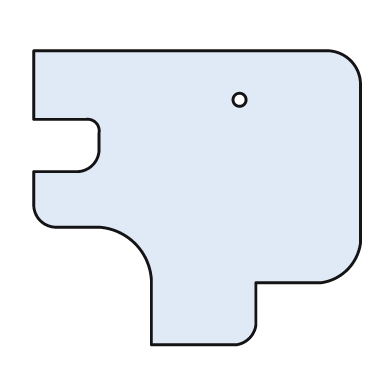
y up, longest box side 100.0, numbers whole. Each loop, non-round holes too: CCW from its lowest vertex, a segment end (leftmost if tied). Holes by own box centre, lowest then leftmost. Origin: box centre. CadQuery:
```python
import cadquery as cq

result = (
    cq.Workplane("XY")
    .moveTo(-14.0, -45.0)
    .lineTo(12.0, -45.0)
    .threePointArc((16.0, -43.0), (18.0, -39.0))
    .lineTo(18.0, -26.0)
    .lineTo(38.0, -26.0)
    .threePointArc((46.0, -22.0), (50.0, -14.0))
    .lineTo(50.0, 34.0)
    .threePointArc((47.0, 42.0), (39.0, 45.0))
    .lineTo(-50.0, 45.0)
    .lineTo(-50.0, 24.0)
    .lineTo(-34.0, 24.0)
    .threePointArc((-31.0, 23.0), (-30.0, 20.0))
    .lineTo(-30.0, 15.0)
    .threePointArc((-32.0, 10.0), (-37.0, 8.0))
    .lineTo(-50.0, 8.0)
    .lineTo(-50.0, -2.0)
    .threePointArc((-48.0, -7.0), (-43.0, -9.0))
    .lineTo(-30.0, -9.0)
    .threePointArc((-19.0, -14.0), (-14.0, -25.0))
    .close()
    .moveTo(13.0, 30.0)
    .circle(2.0)
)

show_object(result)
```